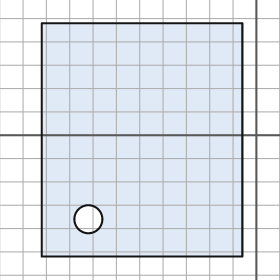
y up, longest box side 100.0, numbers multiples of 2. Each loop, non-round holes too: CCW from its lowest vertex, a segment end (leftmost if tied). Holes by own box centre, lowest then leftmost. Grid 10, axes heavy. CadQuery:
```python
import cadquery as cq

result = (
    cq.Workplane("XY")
    .moveTo(-92.0, -52.0)
    .lineTo(-6.0, -52.0)
    .lineTo(-6.0, 48.0)
    .lineTo(-92.0, 48.0)
    .close()
    .moveTo(-72.0, -36.0)
    .circle(6.0)
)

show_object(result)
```